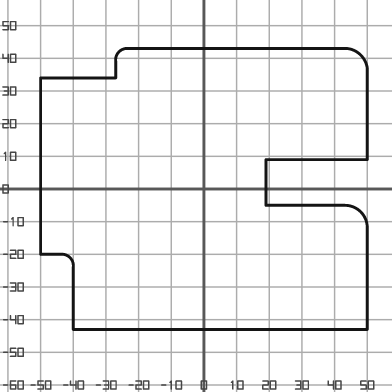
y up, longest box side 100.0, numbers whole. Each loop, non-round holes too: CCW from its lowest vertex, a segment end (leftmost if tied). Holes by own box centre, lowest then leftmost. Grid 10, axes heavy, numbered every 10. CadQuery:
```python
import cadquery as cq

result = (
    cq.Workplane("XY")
    .moveTo(-40.0, -43.0)
    .lineTo(50.0, -43.0)
    .lineTo(50.0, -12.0)
    .threePointArc((48.0, -7.0), (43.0, -5.0))
    .lineTo(19.0, -5.0)
    .lineTo(19.0, 9.0)
    .lineTo(50.0, 9.0)
    .lineTo(50.0, 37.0)
    .threePointArc((48.0, 41.0), (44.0, 43.0))
    .lineTo(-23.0, 43.0)
    .threePointArc((-26.0, 42.0), (-27.0, 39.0))
    .lineTo(-27.0, 34.0)
    .lineTo(-50.0, 34.0)
    .lineTo(-50.0, -20.0)
    .lineTo(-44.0, -20.0)
    .threePointArc((-41.0, -21.0), (-40.0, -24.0))
    .close()
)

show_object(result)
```